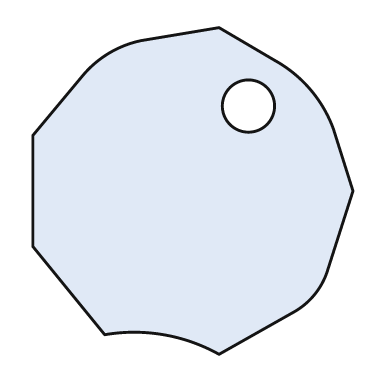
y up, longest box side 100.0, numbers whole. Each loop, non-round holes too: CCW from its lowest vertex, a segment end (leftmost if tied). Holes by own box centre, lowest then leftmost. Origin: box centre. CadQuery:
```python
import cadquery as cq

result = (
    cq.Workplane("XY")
    .moveTo(8.0, -50.0)
    .lineTo(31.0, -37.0)
    .threePointArc((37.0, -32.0), (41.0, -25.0))
    .lineTo(49.0, 0.0)
    .lineTo(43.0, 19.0)
    .threePointArc((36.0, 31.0), (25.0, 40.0))
    .lineTo(8.0, 50.0)
    .lineTo(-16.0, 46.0)
    .threePointArc((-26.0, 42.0), (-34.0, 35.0))
    .lineTo(-49.0, 17.0)
    .lineTo(-49.0, -17.0)
    .lineTo(-27.0, -44.0)
    .threePointArc((-9.0, -44.0), (8.0, -50.0))
    .close()
    .moveTo(17.0, 26.0)
    .circle(8.0)
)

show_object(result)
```